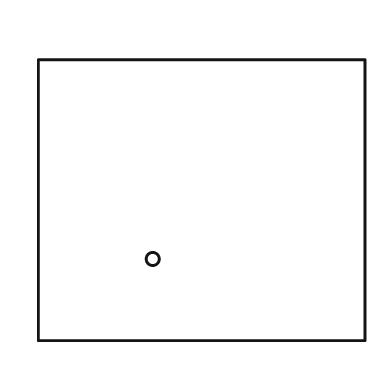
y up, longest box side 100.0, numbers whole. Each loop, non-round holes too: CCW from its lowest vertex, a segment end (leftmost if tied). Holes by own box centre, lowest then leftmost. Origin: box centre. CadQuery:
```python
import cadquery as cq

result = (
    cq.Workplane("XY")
    .moveTo(-50.0, -43.0)
    .lineTo(50.0, -43.0)
    .lineTo(50.0, 43.0)
    .lineTo(-50.0, 43.0)
    .close()
    .moveTo(-15.0, -18.0)
    .circle(2.0)
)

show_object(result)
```